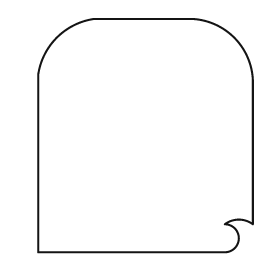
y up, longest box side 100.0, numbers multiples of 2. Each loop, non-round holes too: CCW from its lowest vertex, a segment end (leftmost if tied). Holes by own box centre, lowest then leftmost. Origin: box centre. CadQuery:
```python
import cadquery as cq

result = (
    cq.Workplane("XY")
    .moveTo(-46.0, -50.0)
    .lineTo(34.0, -50.0)
    .threePointArc((40.0, -44.0), (34.0, -38.0))
    .threePointArc((40.0, -36.0), (46.0, -38.0))
    .lineTo(46.0, 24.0)
    .threePointArc((38.0, 42.0), (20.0, 50.0))
    .lineTo(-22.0, 50.0)
    .threePointArc((-38.0, 42.0), (-46.0, 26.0))
    .close()
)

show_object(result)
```